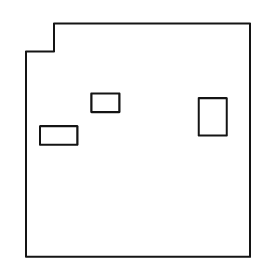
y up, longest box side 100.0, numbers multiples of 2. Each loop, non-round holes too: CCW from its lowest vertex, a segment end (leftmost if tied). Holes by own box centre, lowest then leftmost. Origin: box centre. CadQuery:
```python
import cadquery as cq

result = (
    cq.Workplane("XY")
    .moveTo(-48.0, -50.0)
    .lineTo(48.0, -50.0)
    .lineTo(48.0, 50.0)
    .lineTo(-36.0, 50.0)
    .lineTo(-36.0, 38.0)
    .lineTo(-48.0, 38.0)
    .close()
    .moveTo(-42.0, -2.0)
    .lineTo(-26.0, -2.0)
    .lineTo(-26.0, 6.0)
    .lineTo(-42.0, 6.0)
    .close()
    .moveTo(26.0, 2.0)
    .lineTo(38.0, 2.0)
    .lineTo(38.0, 18.0)
    .lineTo(26.0, 18.0)
    .close()
    .moveTo(-20.0, 12.0)
    .lineTo(-8.0, 12.0)
    .lineTo(-8.0, 20.0)
    .lineTo(-20.0, 20.0)
    .close()
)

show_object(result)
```